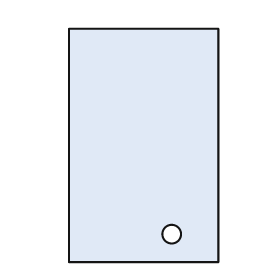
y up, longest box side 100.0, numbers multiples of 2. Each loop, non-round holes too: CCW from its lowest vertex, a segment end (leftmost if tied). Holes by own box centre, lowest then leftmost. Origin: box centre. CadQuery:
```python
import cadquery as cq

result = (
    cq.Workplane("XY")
    .moveTo(-32.0, -50.0)
    .lineTo(32.0, -50.0)
    .lineTo(32.0, 50.0)
    .lineTo(-32.0, 50.0)
    .close()
    .moveTo(12.0, -38.0)
    .circle(4.0)
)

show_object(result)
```